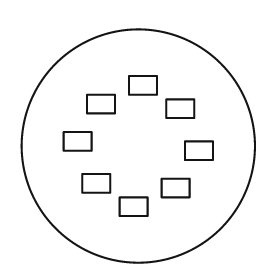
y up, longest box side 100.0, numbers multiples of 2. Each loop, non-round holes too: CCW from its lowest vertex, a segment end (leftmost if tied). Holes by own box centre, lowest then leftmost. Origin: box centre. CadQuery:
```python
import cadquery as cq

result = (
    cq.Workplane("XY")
    .moveTo(0.0, 0.0)
    .circle(50.0)
    .moveTo(-8.0, -30.0)
    .lineTo(4.0, -30.0)
    .lineTo(4.0, -22.0)
    .lineTo(-8.0, -22.0)
    .close()
    .moveTo(10.0, -22.0)
    .lineTo(22.0, -22.0)
    .lineTo(22.0, -14.0)
    .lineTo(10.0, -14.0)
    .close()
    .moveTo(-24.0, -20.0)
    .lineTo(-12.0, -20.0)
    .lineTo(-12.0, -12.0)
    .lineTo(-24.0, -12.0)
    .close()
    .moveTo(20.0, -6.0)
    .lineTo(32.0, -6.0)
    .lineTo(32.0, 2.0)
    .lineTo(20.0, 2.0)
    .close()
    .moveTo(-32.0, -2.0)
    .lineTo(-20.0, -2.0)
    .lineTo(-20.0, 6.0)
    .lineTo(-32.0, 6.0)
    .close()
    .moveTo(12.0, 12.0)
    .lineTo(24.0, 12.0)
    .lineTo(24.0, 20.0)
    .lineTo(12.0, 20.0)
    .close()
    .moveTo(-22.0, 14.0)
    .lineTo(-10.0, 14.0)
    .lineTo(-10.0, 22.0)
    .lineTo(-22.0, 22.0)
    .close()
    .moveTo(-4.0, 22.0)
    .lineTo(8.0, 22.0)
    .lineTo(8.0, 30.0)
    .lineTo(-4.0, 30.0)
    .close()
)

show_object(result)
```